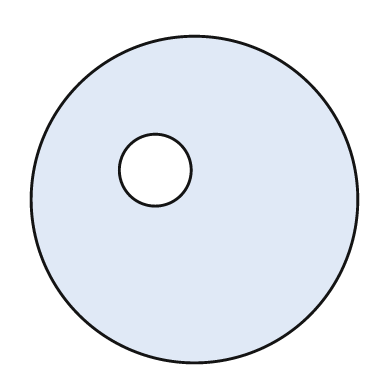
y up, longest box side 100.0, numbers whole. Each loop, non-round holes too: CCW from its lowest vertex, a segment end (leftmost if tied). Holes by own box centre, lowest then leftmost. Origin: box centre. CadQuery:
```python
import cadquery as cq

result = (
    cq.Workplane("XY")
    .moveTo(0.0, 0.0)
    .circle(50.0)
    .moveTo(-12.0, 9.0)
    .circle(11.0)
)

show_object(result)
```